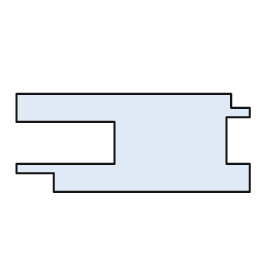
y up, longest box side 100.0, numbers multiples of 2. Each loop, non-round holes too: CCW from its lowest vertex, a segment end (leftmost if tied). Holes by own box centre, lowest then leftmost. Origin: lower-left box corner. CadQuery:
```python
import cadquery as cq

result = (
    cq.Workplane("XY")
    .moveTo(16.0, 0.0)
    .lineTo(100.0, 0.0)
    .lineTo(100.0, 12.0)
    .lineTo(90.0, 12.0)
    .lineTo(90.0, 32.0)
    .lineTo(100.0, 32.0)
    .lineTo(100.0, 36.0)
    .lineTo(92.0, 36.0)
    .lineTo(92.0, 42.0)
    .lineTo(0.0, 42.0)
    .lineTo(0.0, 30.0)
    .lineTo(42.0, 30.0)
    .lineTo(42.0, 12.0)
    .lineTo(0.0, 12.0)
    .lineTo(0.0, 8.0)
    .lineTo(16.0, 8.0)
    .close()
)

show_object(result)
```